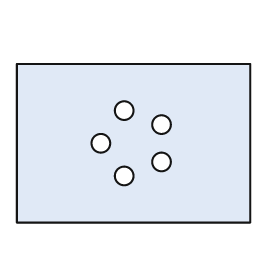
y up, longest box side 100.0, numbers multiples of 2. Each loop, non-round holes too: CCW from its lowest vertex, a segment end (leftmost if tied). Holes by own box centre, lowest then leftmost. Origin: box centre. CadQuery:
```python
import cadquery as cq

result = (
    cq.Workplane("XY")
    .moveTo(-50.0, -34.0)
    .lineTo(50.0, -34.0)
    .lineTo(50.0, 34.0)
    .lineTo(-50.0, 34.0)
    .close()
    .moveTo(-4.0, -14.0)
    .circle(4.0)
    .moveTo(12.0, -8.0)
    .circle(4.0)
    .moveTo(-14.0, 0.0)
    .circle(4.0)
    .moveTo(12.0, 8.0)
    .circle(4.0)
    .moveTo(-4.0, 14.0)
    .circle(4.0)
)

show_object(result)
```